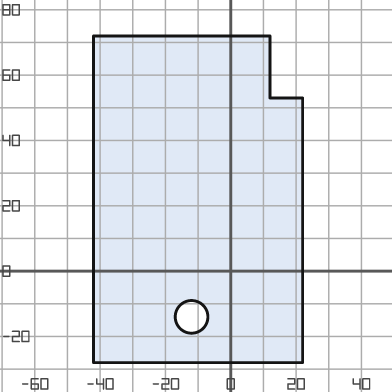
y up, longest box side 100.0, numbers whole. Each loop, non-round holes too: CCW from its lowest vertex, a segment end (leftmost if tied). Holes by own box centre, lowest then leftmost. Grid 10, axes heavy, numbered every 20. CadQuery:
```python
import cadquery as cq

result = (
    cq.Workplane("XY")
    .moveTo(-42.0, -28.0)
    .lineTo(22.0, -28.0)
    .lineTo(22.0, 53.0)
    .lineTo(12.0, 53.0)
    .lineTo(12.0, 72.0)
    .lineTo(-42.0, 72.0)
    .close()
    .moveTo(-12.0, -14.0)
    .circle(5.0)
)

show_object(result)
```